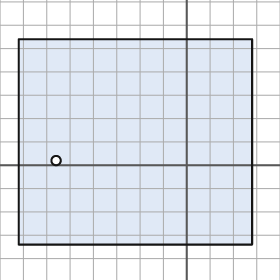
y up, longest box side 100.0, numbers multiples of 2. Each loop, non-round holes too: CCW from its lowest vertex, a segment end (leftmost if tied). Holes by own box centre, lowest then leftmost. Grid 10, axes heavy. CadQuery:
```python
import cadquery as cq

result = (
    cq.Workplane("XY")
    .moveTo(-72.0, -34.0)
    .lineTo(28.0, -34.0)
    .lineTo(28.0, 54.0)
    .lineTo(-72.0, 54.0)
    .close()
    .moveTo(-56.0, 2.0)
    .circle(2.0)
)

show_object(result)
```